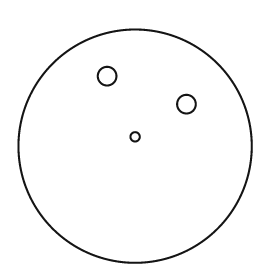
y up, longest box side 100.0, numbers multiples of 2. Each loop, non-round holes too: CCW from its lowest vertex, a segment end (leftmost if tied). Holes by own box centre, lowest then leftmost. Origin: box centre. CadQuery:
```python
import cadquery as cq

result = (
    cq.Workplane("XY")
    .moveTo(0.0, 0.0)
    .circle(50.0)
    .moveTo(0.0, 4.0)
    .circle(2.0)
    .moveTo(22.0, 18.0)
    .circle(4.0)
    .moveTo(-12.0, 30.0)
    .circle(4.0)
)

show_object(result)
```